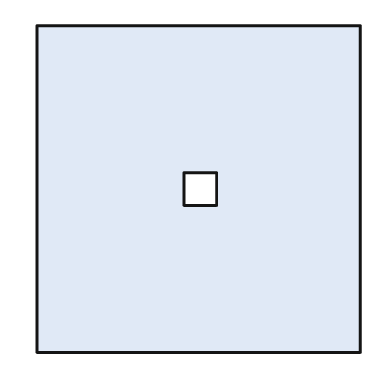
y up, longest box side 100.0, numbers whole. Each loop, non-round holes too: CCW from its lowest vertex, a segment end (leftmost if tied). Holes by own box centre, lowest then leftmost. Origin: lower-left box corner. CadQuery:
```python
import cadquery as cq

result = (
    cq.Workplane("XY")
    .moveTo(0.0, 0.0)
    .lineTo(99.0, 0.0)
    .lineTo(99.0, 100.0)
    .lineTo(0.0, 100.0)
    .close()
    .moveTo(45.0, 45.0)
    .lineTo(55.0, 45.0)
    .lineTo(55.0, 55.0)
    .lineTo(45.0, 55.0)
    .close()
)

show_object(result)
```